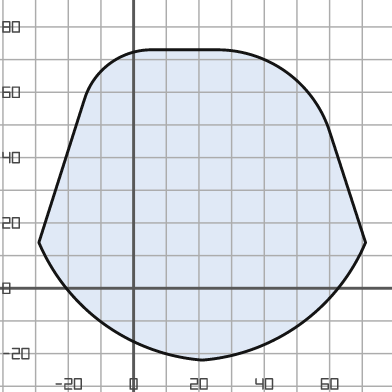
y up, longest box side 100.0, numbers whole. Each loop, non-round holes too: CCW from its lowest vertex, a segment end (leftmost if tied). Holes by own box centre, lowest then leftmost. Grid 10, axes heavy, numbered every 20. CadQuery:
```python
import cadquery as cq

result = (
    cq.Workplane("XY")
    .moveTo(21.0, -22.0)
    .threePointArc((51.0, -11.0), (71.0, 14.0))
    .lineTo(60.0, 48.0)
    .threePointArc((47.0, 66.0), (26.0, 73.0))
    .lineTo(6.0, 73.0)
    .threePointArc((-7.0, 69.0), (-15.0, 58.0))
    .lineTo(-29.0, 14.0)
    .threePointArc((-9.0, -11.0), (21.0, -22.0))
    .close()
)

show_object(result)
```